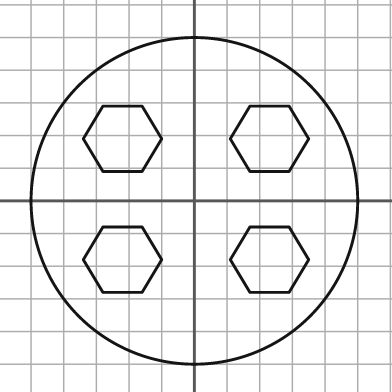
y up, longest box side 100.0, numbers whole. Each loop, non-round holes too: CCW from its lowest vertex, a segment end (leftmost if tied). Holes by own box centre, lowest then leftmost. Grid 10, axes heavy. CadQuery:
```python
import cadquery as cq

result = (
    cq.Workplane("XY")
    .moveTo(0.0, 0.0)
    .circle(50.0)
    .moveTo(-28.0, -28.0)
    .lineTo(-16.0, -28.0)
    .lineTo(-10.0, -18.0)
    .lineTo(-16.0, -8.0)
    .lineTo(-28.0, -8.0)
    .lineTo(-34.0, -18.0)
    .close()
    .moveTo(17.0, -28.0)
    .lineTo(29.0, -28.0)
    .lineTo(35.0, -18.0)
    .lineTo(29.0, -8.0)
    .lineTo(17.0, -8.0)
    .lineTo(11.0, -18.0)
    .close()
    .moveTo(-28.0, 9.0)
    .lineTo(-16.0, 9.0)
    .lineTo(-10.0, 19.0)
    .lineTo(-16.0, 29.0)
    .lineTo(-28.0, 29.0)
    .lineTo(-34.0, 19.0)
    .close()
    .moveTo(17.0, 9.0)
    .lineTo(29.0, 9.0)
    .lineTo(35.0, 19.0)
    .lineTo(29.0, 29.0)
    .lineTo(17.0, 29.0)
    .lineTo(11.0, 19.0)
    .close()
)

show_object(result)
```